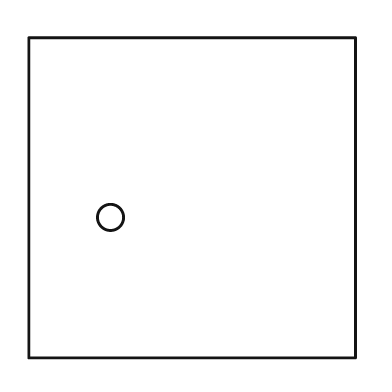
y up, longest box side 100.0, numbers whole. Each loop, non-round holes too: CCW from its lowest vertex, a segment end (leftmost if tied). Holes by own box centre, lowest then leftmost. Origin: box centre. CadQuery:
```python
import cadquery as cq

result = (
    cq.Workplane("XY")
    .moveTo(-50.0, -49.0)
    .lineTo(50.0, -49.0)
    .lineTo(50.0, 49.0)
    .lineTo(-50.0, 49.0)
    .close()
    .moveTo(-25.0, -6.0)
    .circle(4.0)
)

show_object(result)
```